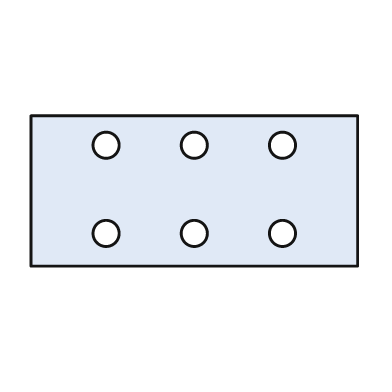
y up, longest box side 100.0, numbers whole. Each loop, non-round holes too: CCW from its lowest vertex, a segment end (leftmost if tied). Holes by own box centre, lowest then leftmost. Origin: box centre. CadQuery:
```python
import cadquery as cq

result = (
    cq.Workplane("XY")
    .moveTo(-50.0, -23.0)
    .lineTo(50.0, -23.0)
    .lineTo(50.0, 23.0)
    .lineTo(-50.0, 23.0)
    .close()
    .moveTo(-27.0, -13.0)
    .circle(4.0)
    .moveTo(0.0, -13.0)
    .circle(4.0)
    .moveTo(27.0, -13.0)
    .circle(4.0)
    .moveTo(-27.0, 14.0)
    .circle(4.0)
    .moveTo(0.0, 14.0)
    .circle(4.0)
    .moveTo(27.0, 14.0)
    .circle(4.0)
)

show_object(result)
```